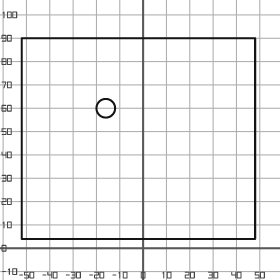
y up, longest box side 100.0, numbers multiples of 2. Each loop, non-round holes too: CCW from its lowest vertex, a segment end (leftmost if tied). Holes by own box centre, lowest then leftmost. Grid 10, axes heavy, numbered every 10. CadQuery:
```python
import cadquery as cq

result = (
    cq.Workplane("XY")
    .moveTo(-52.0, 4.0)
    .lineTo(48.0, 4.0)
    .lineTo(48.0, 90.0)
    .lineTo(-52.0, 90.0)
    .close()
    .moveTo(-16.0, 60.0)
    .circle(4.0)
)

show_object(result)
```